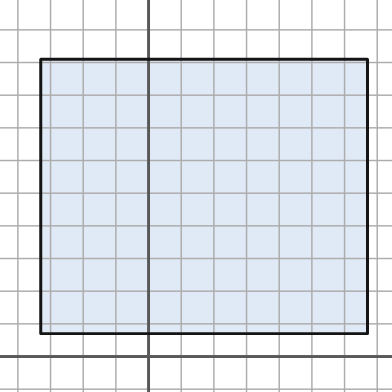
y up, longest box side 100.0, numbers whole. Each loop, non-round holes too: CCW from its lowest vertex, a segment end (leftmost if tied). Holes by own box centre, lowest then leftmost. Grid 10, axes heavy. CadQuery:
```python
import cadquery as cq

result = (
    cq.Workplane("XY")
    .moveTo(-33.0, 7.0)
    .lineTo(67.0, 7.0)
    .lineTo(67.0, 91.0)
    .lineTo(-33.0, 91.0)
    .close()
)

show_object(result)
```